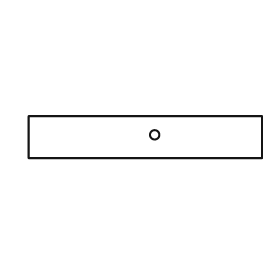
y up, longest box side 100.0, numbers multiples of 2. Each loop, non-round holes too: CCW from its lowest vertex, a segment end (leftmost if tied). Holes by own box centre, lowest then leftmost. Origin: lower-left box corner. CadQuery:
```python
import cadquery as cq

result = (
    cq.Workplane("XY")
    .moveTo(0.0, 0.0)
    .lineTo(100.0, 0.0)
    .lineTo(100.0, 18.0)
    .lineTo(0.0, 18.0)
    .close()
    .moveTo(54.0, 10.0)
    .circle(2.0)
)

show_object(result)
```